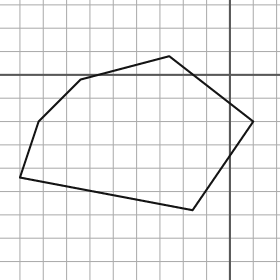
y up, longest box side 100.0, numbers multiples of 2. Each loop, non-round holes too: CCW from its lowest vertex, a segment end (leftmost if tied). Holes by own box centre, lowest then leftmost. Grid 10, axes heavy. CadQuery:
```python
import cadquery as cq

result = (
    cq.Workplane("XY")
    .moveTo(-16.0, -58.0)
    .lineTo(10.0, -20.0)
    .lineTo(-26.0, 8.0)
    .lineTo(-64.0, -2.0)
    .lineTo(-82.0, -20.0)
    .lineTo(-90.0, -44.0)
    .close()
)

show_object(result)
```